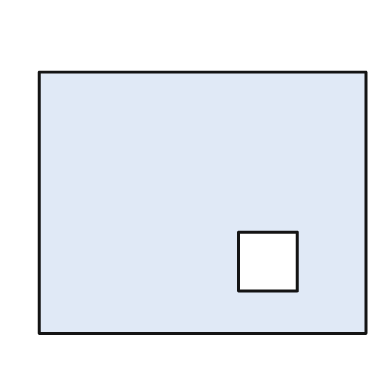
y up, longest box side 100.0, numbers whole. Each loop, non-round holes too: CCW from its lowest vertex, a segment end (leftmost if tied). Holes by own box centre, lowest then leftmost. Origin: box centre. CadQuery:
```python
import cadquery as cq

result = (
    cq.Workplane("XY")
    .moveTo(-50.0, -40.0)
    .lineTo(50.0, -40.0)
    .lineTo(50.0, 40.0)
    .lineTo(-50.0, 40.0)
    .close()
    .moveTo(11.0, -27.0)
    .lineTo(29.0, -27.0)
    .lineTo(29.0, -9.0)
    .lineTo(11.0, -9.0)
    .close()
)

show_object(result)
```